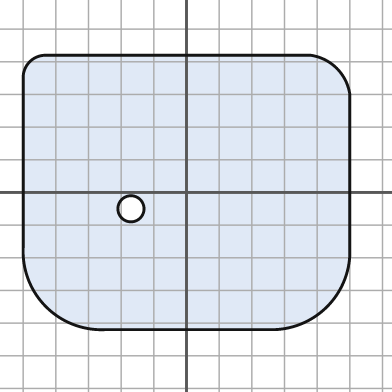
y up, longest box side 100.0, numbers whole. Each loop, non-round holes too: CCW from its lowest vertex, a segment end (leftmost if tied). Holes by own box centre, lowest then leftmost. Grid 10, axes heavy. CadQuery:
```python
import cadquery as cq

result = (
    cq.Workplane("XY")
    .moveTo(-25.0, -42.0)
    .lineTo(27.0, -42.0)
    .threePointArc((43.0, -35.0), (50.0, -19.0))
    .lineTo(50.0, 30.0)
    .threePointArc((46.0, 38.0), (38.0, 42.0))
    .lineTo(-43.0, 42.0)
    .threePointArc((-48.0, 40.0), (-50.0, 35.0))
    .lineTo(-50.0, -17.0)
    .threePointArc((-43.0, -35.0), (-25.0, -42.0))
    .close()
    .moveTo(-17.0, -5.0)
    .circle(4.0)
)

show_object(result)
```